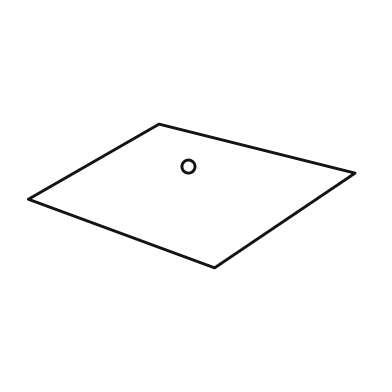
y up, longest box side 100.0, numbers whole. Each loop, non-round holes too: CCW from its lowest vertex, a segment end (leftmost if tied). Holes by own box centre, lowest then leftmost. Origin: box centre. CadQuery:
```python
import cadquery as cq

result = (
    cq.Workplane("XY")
    .moveTo(7.0, -22.0)
    .lineTo(50.0, 7.0)
    .lineTo(-10.0, 22.0)
    .lineTo(-50.0, -1.0)
    .close()
    .moveTo(-1.0, 9.0)
    .circle(2.0)
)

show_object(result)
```